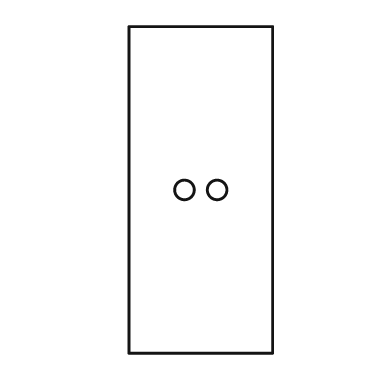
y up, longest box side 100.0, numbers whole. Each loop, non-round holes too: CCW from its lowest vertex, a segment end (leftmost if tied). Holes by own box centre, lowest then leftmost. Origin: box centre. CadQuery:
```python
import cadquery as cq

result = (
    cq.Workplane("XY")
    .moveTo(-22.0, -50.0)
    .lineTo(22.0, -50.0)
    .lineTo(22.0, 50.0)
    .lineTo(-22.0, 50.0)
    .close()
    .moveTo(-5.0, 0.0)
    .circle(3.0)
    .moveTo(5.0, 0.0)
    .circle(3.0)
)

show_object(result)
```